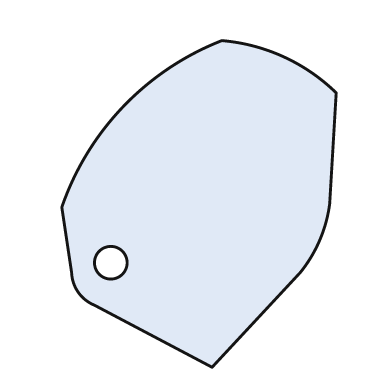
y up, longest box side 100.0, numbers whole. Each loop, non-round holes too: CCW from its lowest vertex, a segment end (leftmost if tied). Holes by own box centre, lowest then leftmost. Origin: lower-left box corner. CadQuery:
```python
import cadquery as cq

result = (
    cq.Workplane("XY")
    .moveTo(46.0, 0.0)
    .lineTo(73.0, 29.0)
    .threePointArc((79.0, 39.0), (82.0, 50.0))
    .lineTo(84.0, 84.0)
    .threePointArc((68.0, 95.0), (49.0, 100.0))
    .threePointArc((19.0, 80.0), (0.0, 49.0))
    .lineTo(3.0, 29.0)
    .threePointArc((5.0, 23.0), (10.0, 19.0))
    .close()
    .moveTo(15.0, 32.0)
    .circle(5.0)
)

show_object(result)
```